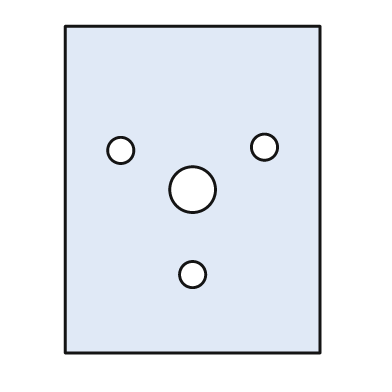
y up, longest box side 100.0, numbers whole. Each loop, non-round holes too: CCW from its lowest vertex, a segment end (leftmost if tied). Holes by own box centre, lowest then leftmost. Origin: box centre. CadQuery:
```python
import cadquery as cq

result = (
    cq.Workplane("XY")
    .moveTo(-39.0, -50.0)
    .lineTo(39.0, -50.0)
    .lineTo(39.0, 50.0)
    .lineTo(-39.0, 50.0)
    .close()
    .moveTo(0.0, -26.0)
    .circle(4.0)
    .moveTo(0.0, 0.0)
    .circle(7.0)
    .moveTo(-22.0, 12.0)
    .circle(4.0)
    .moveTo(22.0, 13.0)
    .circle(4.0)
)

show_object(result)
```